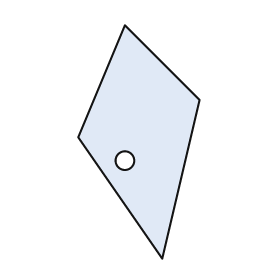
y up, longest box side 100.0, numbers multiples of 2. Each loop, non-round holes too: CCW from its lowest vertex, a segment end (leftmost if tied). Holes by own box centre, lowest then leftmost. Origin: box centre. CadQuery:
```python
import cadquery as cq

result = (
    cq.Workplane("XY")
    .moveTo(10.0, -50.0)
    .lineTo(26.0, 18.0)
    .lineTo(-6.0, 50.0)
    .lineTo(-26.0, 2.0)
    .close()
    .moveTo(-6.0, -8.0)
    .circle(4.0)
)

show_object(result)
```